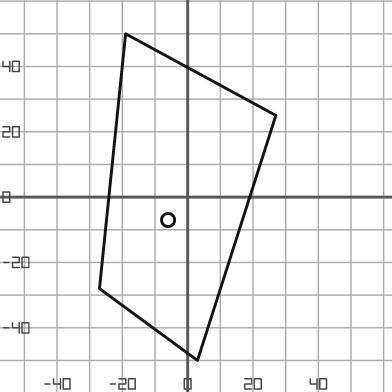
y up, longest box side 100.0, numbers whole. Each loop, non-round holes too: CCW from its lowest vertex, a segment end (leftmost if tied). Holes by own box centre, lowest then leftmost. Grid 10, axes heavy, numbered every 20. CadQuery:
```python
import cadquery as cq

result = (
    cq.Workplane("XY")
    .moveTo(3.0, -50.0)
    .lineTo(27.0, 25.0)
    .lineTo(-19.0, 50.0)
    .lineTo(-27.0, -28.0)
    .close()
    .moveTo(-6.0, -7.0)
    .circle(2.0)
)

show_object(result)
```